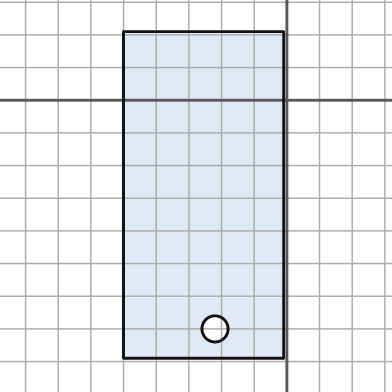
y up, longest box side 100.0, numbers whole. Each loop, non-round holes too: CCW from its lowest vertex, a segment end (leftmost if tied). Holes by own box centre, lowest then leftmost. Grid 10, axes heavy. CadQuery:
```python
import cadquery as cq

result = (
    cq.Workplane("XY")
    .moveTo(-50.0, -79.0)
    .lineTo(-1.0, -79.0)
    .lineTo(-1.0, 21.0)
    .lineTo(-50.0, 21.0)
    .close()
    .moveTo(-22.0, -70.0)
    .circle(4.0)
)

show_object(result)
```